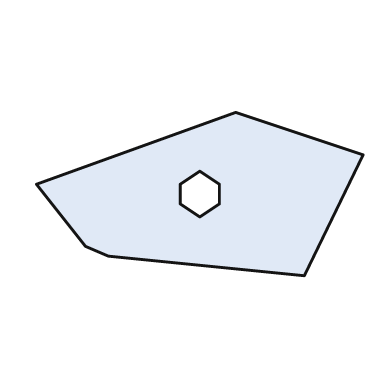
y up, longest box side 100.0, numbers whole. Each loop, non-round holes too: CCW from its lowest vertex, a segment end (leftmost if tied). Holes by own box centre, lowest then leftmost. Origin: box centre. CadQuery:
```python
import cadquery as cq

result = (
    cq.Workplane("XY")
    .moveTo(32.0, -25.0)
    .lineTo(50.0, 12.0)
    .lineTo(11.0, 25.0)
    .lineTo(-50.0, 3.0)
    .lineTo(-35.0, -16.0)
    .lineTo(-28.0, -19.0)
    .close()
    .moveTo(0.0, -7.0)
    .lineTo(6.0, -3.0)
    .lineTo(6.0, 3.0)
    .lineTo(0.0, 7.0)
    .lineTo(-6.0, 3.0)
    .lineTo(-6.0, -3.0)
    .close()
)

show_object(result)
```